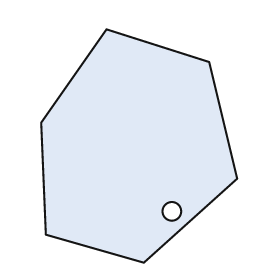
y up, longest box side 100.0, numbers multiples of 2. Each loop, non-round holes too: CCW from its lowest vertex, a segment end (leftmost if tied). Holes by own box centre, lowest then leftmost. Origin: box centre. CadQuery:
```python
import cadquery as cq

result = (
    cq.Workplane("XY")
    .moveTo(2.0, -50.0)
    .lineTo(42.0, -14.0)
    .lineTo(30.0, 36.0)
    .lineTo(-14.0, 50.0)
    .lineTo(-42.0, 10.0)
    .lineTo(-40.0, -38.0)
    .close()
    .moveTo(14.0, -28.0)
    .circle(4.0)
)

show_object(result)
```